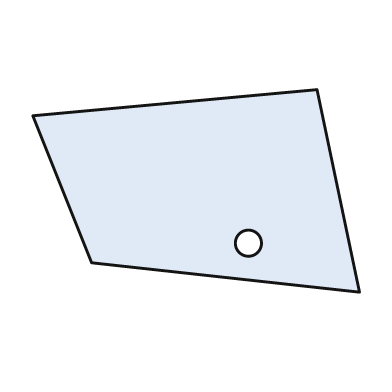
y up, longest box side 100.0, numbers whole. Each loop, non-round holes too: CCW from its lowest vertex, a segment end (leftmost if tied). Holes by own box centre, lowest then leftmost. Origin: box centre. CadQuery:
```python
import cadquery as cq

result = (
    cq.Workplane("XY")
    .moveTo(50.0, -31.0)
    .lineTo(37.0, 31.0)
    .lineTo(-50.0, 23.0)
    .lineTo(-32.0, -22.0)
    .close()
    .moveTo(16.0, -16.0)
    .circle(4.0)
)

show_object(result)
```